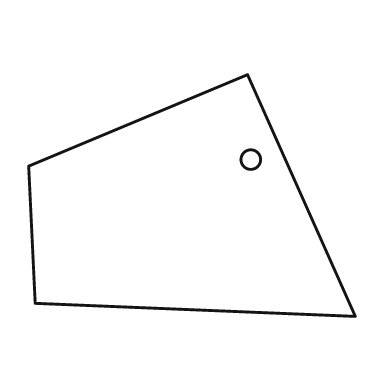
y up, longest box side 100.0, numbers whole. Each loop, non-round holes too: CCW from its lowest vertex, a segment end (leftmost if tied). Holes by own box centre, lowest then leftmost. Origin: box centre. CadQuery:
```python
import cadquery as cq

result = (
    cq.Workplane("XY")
    .moveTo(50.0, -37.0)
    .lineTo(17.0, 37.0)
    .lineTo(-50.0, 9.0)
    .lineTo(-48.0, -33.0)
    .close()
    .moveTo(18.0, 11.0)
    .circle(3.0)
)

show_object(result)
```